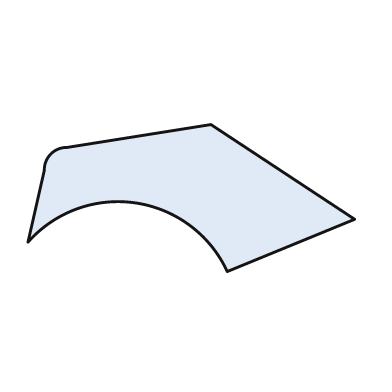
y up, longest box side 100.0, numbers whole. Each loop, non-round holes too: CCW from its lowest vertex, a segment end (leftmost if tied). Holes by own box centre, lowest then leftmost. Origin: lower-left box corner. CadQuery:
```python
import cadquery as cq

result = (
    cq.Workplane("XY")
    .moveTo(61.0, 0.0)
    .lineTo(100.0, 16.0)
    .lineTo(56.0, 45.0)
    .lineTo(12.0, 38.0)
    .threePointArc((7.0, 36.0), (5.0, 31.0))
    .lineTo(0.0, 9.0)
    .threePointArc((33.0, 21.0), (61.0, 0.0))
    .close()
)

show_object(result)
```